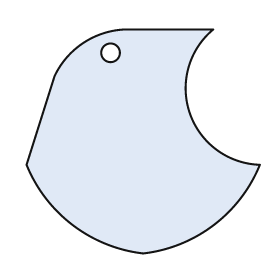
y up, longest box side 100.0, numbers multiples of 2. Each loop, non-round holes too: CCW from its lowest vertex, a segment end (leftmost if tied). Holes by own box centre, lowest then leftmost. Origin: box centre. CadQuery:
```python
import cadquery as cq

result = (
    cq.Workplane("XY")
    .moveTo(0.0, -48.0)
    .threePointArc((30.0, -36.0), (50.0, -10.0))
    .threePointArc((20.0, 12.0), (30.0, 48.0))
    .lineTo(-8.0, 48.0)
    .threePointArc((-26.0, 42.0), (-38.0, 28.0))
    .lineTo(-50.0, -10.0)
    .threePointArc((-30.0, -36.0), (0.0, -48.0))
    .close()
    .moveTo(-14.0, 38.0)
    .circle(4.0)
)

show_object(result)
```